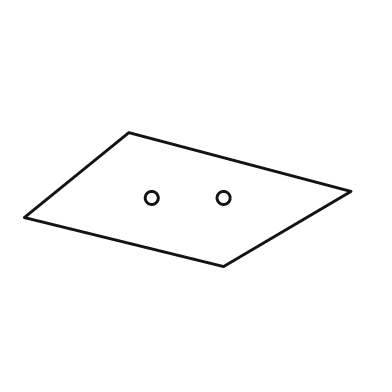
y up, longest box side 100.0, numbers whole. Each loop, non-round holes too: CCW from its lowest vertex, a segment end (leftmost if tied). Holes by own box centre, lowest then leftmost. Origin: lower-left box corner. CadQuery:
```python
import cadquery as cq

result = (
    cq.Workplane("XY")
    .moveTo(61.0, 0.0)
    .lineTo(100.0, 23.0)
    .lineTo(32.0, 41.0)
    .lineTo(0.0, 15.0)
    .close()
    .moveTo(39.0, 21.0)
    .circle(2.0)
    .moveTo(61.0, 21.0)
    .circle(2.0)
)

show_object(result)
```